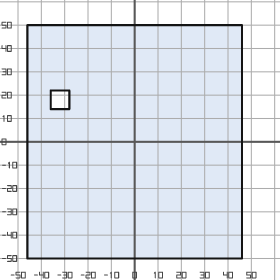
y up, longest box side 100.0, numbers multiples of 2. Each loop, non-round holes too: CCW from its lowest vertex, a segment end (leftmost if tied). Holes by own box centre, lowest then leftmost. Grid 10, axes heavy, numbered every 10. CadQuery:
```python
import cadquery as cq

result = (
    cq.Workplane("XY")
    .moveTo(-46.0, -50.0)
    .lineTo(46.0, -50.0)
    .lineTo(46.0, 50.0)
    .lineTo(-46.0, 50.0)
    .close()
    .moveTo(-36.0, 14.0)
    .lineTo(-28.0, 14.0)
    .lineTo(-28.0, 22.0)
    .lineTo(-36.0, 22.0)
    .close()
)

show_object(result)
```